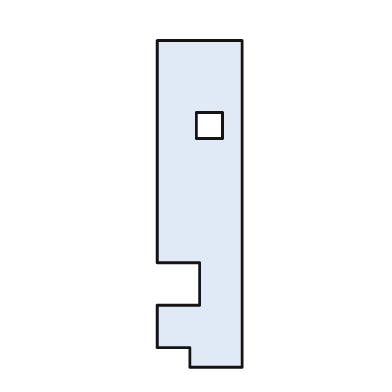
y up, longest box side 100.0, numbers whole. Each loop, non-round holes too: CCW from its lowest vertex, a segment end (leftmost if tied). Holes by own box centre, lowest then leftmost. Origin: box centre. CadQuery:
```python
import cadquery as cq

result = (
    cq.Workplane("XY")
    .moveTo(-3.0, -50.0)
    .lineTo(13.0, -50.0)
    .lineTo(13.0, 50.0)
    .lineTo(-13.0, 50.0)
    .lineTo(-13.0, -18.0)
    .lineTo(0.0, -18.0)
    .lineTo(0.0, -31.0)
    .lineTo(-13.0, -31.0)
    .lineTo(-13.0, -44.0)
    .lineTo(-3.0, -44.0)
    .close()
    .moveTo(-1.0, 20.0)
    .lineTo(7.0, 20.0)
    .lineTo(7.0, 28.0)
    .lineTo(-1.0, 28.0)
    .close()
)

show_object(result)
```